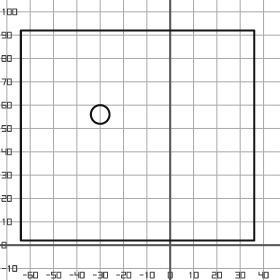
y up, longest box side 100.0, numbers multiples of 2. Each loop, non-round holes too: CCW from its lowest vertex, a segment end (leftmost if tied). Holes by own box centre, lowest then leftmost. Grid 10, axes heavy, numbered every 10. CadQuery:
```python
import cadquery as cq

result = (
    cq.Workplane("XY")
    .moveTo(-64.0, 2.0)
    .lineTo(36.0, 2.0)
    .lineTo(36.0, 92.0)
    .lineTo(-64.0, 92.0)
    .close()
    .moveTo(-30.0, 56.0)
    .circle(4.0)
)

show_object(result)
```